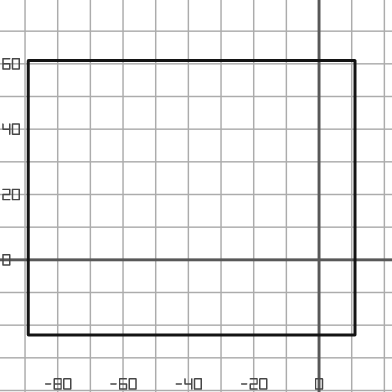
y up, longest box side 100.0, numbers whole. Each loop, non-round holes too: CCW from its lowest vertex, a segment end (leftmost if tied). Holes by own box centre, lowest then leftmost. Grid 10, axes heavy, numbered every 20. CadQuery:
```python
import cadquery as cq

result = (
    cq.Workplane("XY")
    .moveTo(-89.0, -23.0)
    .lineTo(11.0, -23.0)
    .lineTo(11.0, 61.0)
    .lineTo(-89.0, 61.0)
    .close()
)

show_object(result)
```